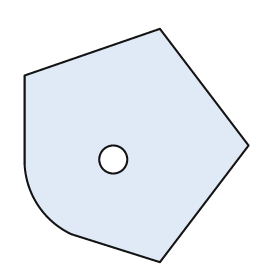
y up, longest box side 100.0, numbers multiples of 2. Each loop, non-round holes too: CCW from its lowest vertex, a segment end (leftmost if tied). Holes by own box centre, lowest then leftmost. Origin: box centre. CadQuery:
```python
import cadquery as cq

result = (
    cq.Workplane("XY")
    .moveTo(10.0, -50.0)
    .lineTo(48.0, 0.0)
    .lineTo(10.0, 50.0)
    .lineTo(-48.0, 30.0)
    .lineTo(-48.0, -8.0)
    .threePointArc((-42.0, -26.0), (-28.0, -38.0))
    .close()
    .moveTo(-10.0, -6.0)
    .circle(6.0)
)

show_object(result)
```